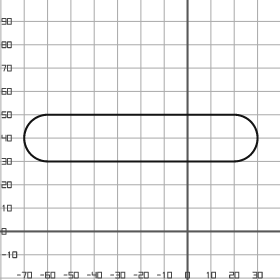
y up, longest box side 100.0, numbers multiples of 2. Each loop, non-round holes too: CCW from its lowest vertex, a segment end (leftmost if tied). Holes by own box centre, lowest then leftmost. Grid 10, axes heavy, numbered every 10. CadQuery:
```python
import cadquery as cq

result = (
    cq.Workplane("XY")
    .moveTo(-60.0, 30.0)
    .lineTo(20.0, 30.0)
    .threePointArc((30.0, 40.0), (20.0, 50.0))
    .lineTo(-60.0, 50.0)
    .threePointArc((-70.0, 40.0), (-60.0, 30.0))
    .close()
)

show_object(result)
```